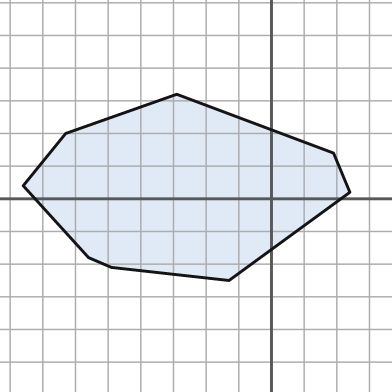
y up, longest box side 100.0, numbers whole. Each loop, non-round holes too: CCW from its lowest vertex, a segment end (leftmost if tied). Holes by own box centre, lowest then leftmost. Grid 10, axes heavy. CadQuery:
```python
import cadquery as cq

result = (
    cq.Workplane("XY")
    .moveTo(-13.0, -25.0)
    .lineTo(24.0, 2.0)
    .lineTo(19.0, 14.0)
    .lineTo(-29.0, 32.0)
    .lineTo(-63.0, 20.0)
    .lineTo(-76.0, 4.0)
    .lineTo(-56.0, -18.0)
    .lineTo(-49.0, -21.0)
    .close()
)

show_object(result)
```